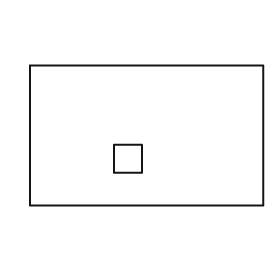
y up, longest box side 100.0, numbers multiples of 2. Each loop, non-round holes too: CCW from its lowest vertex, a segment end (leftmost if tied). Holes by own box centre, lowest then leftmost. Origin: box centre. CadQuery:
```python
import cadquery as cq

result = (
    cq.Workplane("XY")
    .moveTo(-50.0, -30.0)
    .lineTo(50.0, -30.0)
    .lineTo(50.0, 30.0)
    .lineTo(-50.0, 30.0)
    .close()
    .moveTo(-14.0, -16.0)
    .lineTo(-2.0, -16.0)
    .lineTo(-2.0, -4.0)
    .lineTo(-14.0, -4.0)
    .close()
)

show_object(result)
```